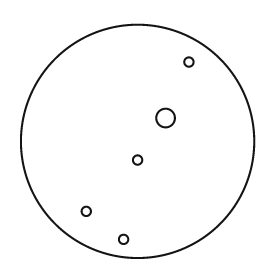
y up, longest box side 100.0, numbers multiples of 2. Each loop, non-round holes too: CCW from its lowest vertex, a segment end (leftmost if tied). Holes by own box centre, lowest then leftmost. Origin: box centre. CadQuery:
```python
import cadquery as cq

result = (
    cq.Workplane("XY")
    .moveTo(0.0, 0.0)
    .circle(50.0)
    .moveTo(-6.0, -42.0)
    .circle(2.0)
    .moveTo(-22.0, -30.0)
    .circle(2.0)
    .moveTo(0.0, -8.0)
    .circle(2.0)
    .moveTo(12.0, 10.0)
    .circle(4.0)
    .moveTo(22.0, 34.0)
    .circle(2.0)
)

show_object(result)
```